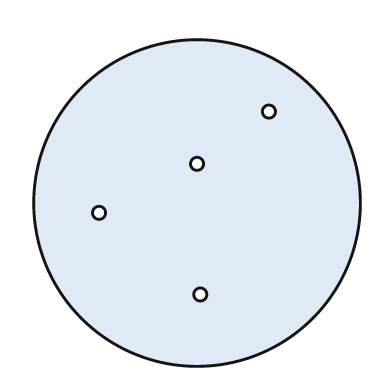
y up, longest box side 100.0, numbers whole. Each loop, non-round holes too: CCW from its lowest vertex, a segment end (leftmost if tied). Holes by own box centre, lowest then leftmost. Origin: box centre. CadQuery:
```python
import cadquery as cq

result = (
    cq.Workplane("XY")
    .moveTo(0.0, 0.0)
    .circle(50.0)
    .moveTo(1.0, -28.0)
    .circle(2.0)
    .moveTo(-30.0, -3.0)
    .circle(2.0)
    .moveTo(0.0, 12.0)
    .circle(2.0)
    .moveTo(22.0, 28.0)
    .circle(2.0)
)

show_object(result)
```